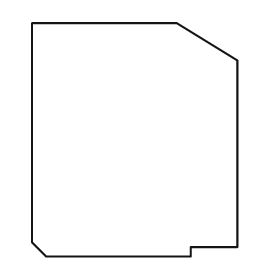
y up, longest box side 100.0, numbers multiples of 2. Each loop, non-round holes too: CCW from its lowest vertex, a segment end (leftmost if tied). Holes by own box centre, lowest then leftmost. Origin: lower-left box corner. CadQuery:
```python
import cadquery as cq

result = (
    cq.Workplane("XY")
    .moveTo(6.0, 0.0)
    .lineTo(68.0, 0.0)
    .lineTo(68.0, 4.0)
    .lineTo(88.0, 4.0)
    .lineTo(88.0, 84.0)
    .lineTo(62.0, 100.0)
    .lineTo(0.0, 100.0)
    .lineTo(0.0, 6.0)
    .close()
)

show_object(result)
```